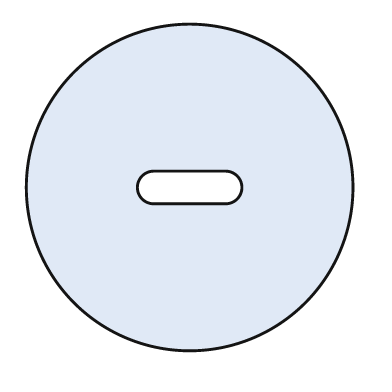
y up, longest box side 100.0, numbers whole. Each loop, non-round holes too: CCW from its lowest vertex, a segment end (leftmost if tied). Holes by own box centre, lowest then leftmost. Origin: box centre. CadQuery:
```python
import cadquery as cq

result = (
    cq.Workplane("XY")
    .moveTo(0.0, 0.0)
    .circle(50.0)
    .moveTo(-11.0, -5.0)
    .lineTo(11.0, -5.0)
    .threePointArc((16.0, 0.0), (11.0, 5.0))
    .lineTo(-11.0, 5.0)
    .threePointArc((-16.0, 0.0), (-11.0, -5.0))
    .close()
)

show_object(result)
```